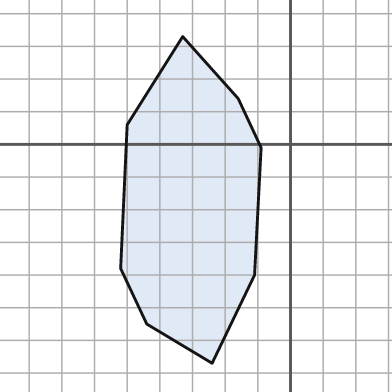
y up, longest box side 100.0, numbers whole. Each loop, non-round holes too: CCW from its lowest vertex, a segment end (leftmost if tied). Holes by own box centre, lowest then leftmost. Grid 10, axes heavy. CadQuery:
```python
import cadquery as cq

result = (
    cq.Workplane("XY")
    .moveTo(-24.0, -67.0)
    .lineTo(-11.0, -40.0)
    .lineTo(-9.0, -1.0)
    .lineTo(-16.0, 14.0)
    .lineTo(-33.0, 33.0)
    .lineTo(-50.0, 6.0)
    .lineTo(-52.0, -38.0)
    .lineTo(-44.0, -55.0)
    .close()
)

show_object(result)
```